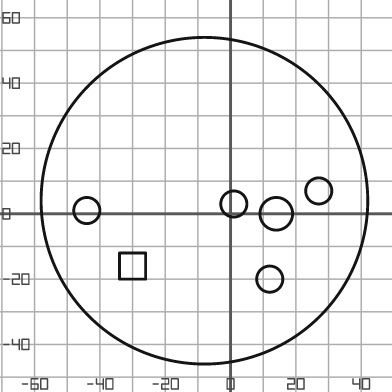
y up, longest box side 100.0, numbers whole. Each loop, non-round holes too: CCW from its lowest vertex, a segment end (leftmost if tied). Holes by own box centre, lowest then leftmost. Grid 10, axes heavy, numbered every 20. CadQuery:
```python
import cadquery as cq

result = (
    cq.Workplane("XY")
    .moveTo(-8.0, 4.0)
    .circle(50.0)
    .moveTo(12.0, -20.0)
    .circle(4.0)
    .moveTo(-34.0, -20.0)
    .lineTo(-26.0, -20.0)
    .lineTo(-26.0, -12.0)
    .lineTo(-34.0, -12.0)
    .close()
    .moveTo(14.0, 0.0)
    .circle(5.0)
    .moveTo(-44.0, 1.0)
    .circle(4.0)
    .moveTo(1.0, 3.0)
    .circle(4.0)
    .moveTo(27.0, 7.0)
    .circle(4.0)
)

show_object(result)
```